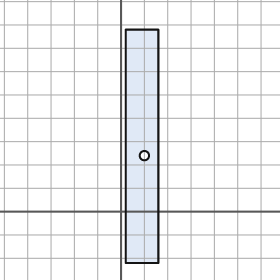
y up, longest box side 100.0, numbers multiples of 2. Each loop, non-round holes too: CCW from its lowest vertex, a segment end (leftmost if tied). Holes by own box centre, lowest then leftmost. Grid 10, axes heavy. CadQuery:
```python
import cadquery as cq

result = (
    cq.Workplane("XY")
    .moveTo(2.0, -22.0)
    .lineTo(16.0, -22.0)
    .lineTo(16.0, 78.0)
    .lineTo(2.0, 78.0)
    .close()
    .moveTo(10.0, 24.0)
    .circle(2.0)
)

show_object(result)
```